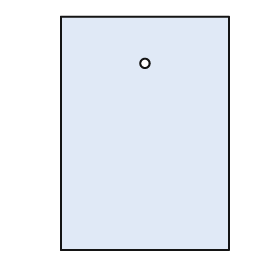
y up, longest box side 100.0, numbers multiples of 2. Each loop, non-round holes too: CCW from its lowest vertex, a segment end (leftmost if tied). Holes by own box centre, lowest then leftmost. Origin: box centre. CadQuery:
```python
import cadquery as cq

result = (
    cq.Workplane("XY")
    .moveTo(-36.0, -50.0)
    .lineTo(36.0, -50.0)
    .lineTo(36.0, 50.0)
    .lineTo(-36.0, 50.0)
    .close()
    .moveTo(0.0, 30.0)
    .circle(2.0)
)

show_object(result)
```